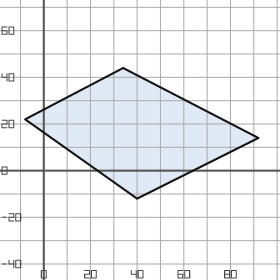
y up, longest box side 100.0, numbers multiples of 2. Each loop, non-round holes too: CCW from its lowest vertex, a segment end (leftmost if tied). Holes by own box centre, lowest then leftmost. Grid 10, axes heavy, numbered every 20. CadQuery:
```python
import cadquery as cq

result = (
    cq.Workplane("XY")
    .moveTo(40.0, -12.0)
    .lineTo(92.0, 14.0)
    .lineTo(34.0, 44.0)
    .lineTo(-8.0, 22.0)
    .close()
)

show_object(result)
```